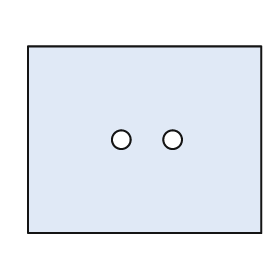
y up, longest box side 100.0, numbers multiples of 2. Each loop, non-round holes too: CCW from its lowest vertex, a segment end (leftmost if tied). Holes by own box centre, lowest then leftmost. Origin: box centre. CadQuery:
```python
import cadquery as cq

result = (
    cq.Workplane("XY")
    .moveTo(-50.0, -40.0)
    .lineTo(50.0, -40.0)
    .lineTo(50.0, 40.0)
    .lineTo(-50.0, 40.0)
    .close()
    .moveTo(-10.0, 0.0)
    .circle(4.0)
    .moveTo(12.0, 0.0)
    .circle(4.0)
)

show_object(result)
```